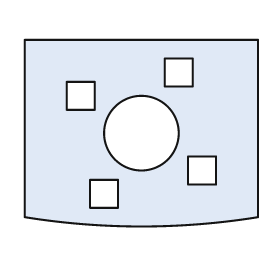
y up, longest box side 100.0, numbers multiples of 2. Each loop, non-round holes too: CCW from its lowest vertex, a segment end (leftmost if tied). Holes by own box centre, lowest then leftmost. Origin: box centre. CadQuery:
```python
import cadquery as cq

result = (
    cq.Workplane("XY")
    .moveTo(-50.0, -36.0)
    .threePointArc((0.0, -40.0), (50.0, -36.0))
    .lineTo(50.0, 40.0)
    .lineTo(-50.0, 40.0)
    .close()
    .moveTo(-22.0, -32.0)
    .lineTo(-10.0, -32.0)
    .lineTo(-10.0, -20.0)
    .lineTo(-22.0, -20.0)
    .close()
    .moveTo(20.0, -22.0)
    .lineTo(32.0, -22.0)
    .lineTo(32.0, -10.0)
    .lineTo(20.0, -10.0)
    .close()
    .moveTo(0.0, 0.0)
    .circle(16.0)
    .moveTo(-32.0, 10.0)
    .lineTo(-20.0, 10.0)
    .lineTo(-20.0, 22.0)
    .lineTo(-32.0, 22.0)
    .close()
    .moveTo(10.0, 20.0)
    .lineTo(22.0, 20.0)
    .lineTo(22.0, 32.0)
    .lineTo(10.0, 32.0)
    .close()
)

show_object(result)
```